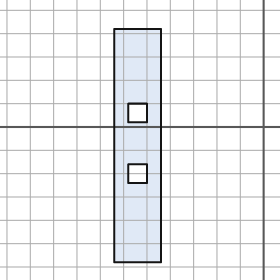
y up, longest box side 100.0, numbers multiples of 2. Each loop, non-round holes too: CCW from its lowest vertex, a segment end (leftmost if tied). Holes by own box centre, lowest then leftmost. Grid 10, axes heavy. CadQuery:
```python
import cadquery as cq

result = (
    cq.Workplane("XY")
    .moveTo(-64.0, -58.0)
    .lineTo(-44.0, -58.0)
    .lineTo(-44.0, 42.0)
    .lineTo(-64.0, 42.0)
    .close()
    .moveTo(-58.0, -24.0)
    .lineTo(-50.0, -24.0)
    .lineTo(-50.0, -16.0)
    .lineTo(-58.0, -16.0)
    .close()
    .moveTo(-58.0, 2.0)
    .lineTo(-50.0, 2.0)
    .lineTo(-50.0, 10.0)
    .lineTo(-58.0, 10.0)
    .close()
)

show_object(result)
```